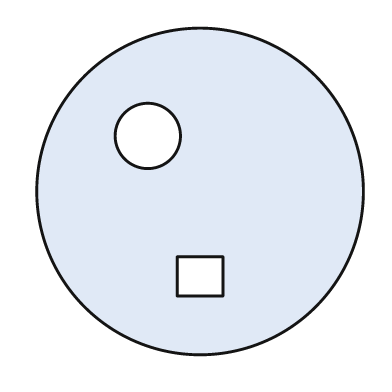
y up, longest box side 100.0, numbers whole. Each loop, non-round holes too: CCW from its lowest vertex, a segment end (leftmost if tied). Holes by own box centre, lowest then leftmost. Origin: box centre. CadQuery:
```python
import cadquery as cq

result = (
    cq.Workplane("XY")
    .moveTo(0.0, 0.0)
    .circle(50.0)
    .moveTo(-7.0, -32.0)
    .lineTo(7.0, -32.0)
    .lineTo(7.0, -20.0)
    .lineTo(-7.0, -20.0)
    .close()
    .moveTo(-16.0, 17.0)
    .circle(10.0)
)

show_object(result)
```